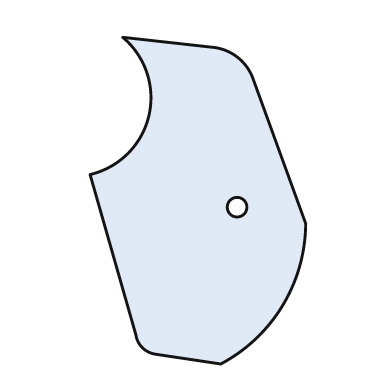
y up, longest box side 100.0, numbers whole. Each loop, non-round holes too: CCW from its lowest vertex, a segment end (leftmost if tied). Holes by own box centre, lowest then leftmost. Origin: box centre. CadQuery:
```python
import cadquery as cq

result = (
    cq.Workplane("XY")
    .moveTo(7.0, -50.0)
    .threePointArc((26.0, -32.0), (33.0, -7.0))
    .lineTo(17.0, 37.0)
    .threePointArc((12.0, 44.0), (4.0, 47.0))
    .lineTo(-23.0, 50.0)
    .threePointArc((-15.0, 26.0), (-33.0, 8.0))
    .lineTo(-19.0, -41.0)
    .threePointArc((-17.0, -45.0), (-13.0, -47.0))
    .close()
    .moveTo(12.0, -2.0)
    .circle(3.0)
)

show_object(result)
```